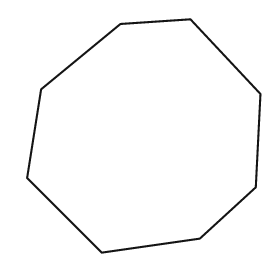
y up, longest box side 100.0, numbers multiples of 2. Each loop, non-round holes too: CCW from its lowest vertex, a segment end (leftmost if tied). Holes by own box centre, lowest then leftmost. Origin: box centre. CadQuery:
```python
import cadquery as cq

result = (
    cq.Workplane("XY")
    .moveTo(-18.0, -50.0)
    .lineTo(24.0, -44.0)
    .lineTo(48.0, -22.0)
    .lineTo(50.0, 18.0)
    .lineTo(20.0, 50.0)
    .lineTo(-10.0, 48.0)
    .lineTo(-44.0, 20.0)
    .lineTo(-50.0, -18.0)
    .close()
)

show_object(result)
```